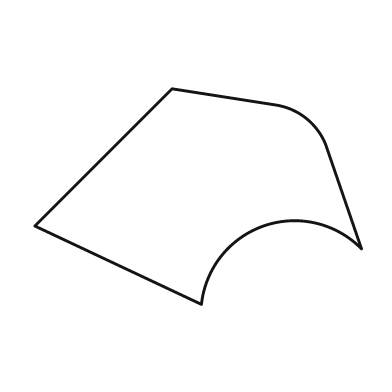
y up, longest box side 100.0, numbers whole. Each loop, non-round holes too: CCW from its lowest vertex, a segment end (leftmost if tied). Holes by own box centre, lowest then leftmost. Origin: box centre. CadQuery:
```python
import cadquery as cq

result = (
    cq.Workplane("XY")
    .moveTo(1.0, -33.0)
    .threePointArc((20.0, -9.0), (50.0, -16.0))
    .lineTo(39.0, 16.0)
    .threePointArc((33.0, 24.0), (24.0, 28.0))
    .lineTo(-8.0, 33.0)
    .lineTo(-50.0, -9.0)
    .close()
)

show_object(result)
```